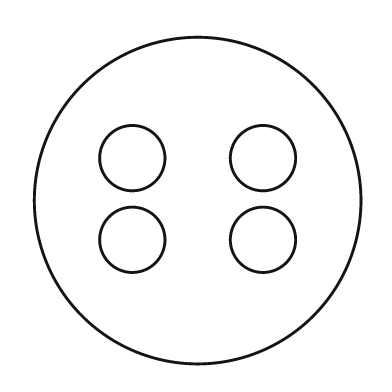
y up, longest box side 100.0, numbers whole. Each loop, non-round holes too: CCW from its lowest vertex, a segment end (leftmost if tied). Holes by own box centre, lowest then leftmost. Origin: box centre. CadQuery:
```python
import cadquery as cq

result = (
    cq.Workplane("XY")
    .moveTo(0.0, 0.0)
    .circle(50.0)
    .moveTo(-20.0, -12.0)
    .circle(10.0)
    .moveTo(20.0, -12.0)
    .circle(10.0)
    .moveTo(-20.0, 13.0)
    .circle(10.0)
    .moveTo(20.0, 13.0)
    .circle(10.0)
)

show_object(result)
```